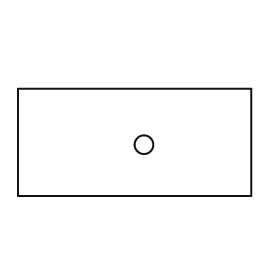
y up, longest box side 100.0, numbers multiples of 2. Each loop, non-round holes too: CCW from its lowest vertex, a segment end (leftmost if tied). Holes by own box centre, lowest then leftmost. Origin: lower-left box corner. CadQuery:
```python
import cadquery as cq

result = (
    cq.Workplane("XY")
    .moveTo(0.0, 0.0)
    .lineTo(100.0, 0.0)
    .lineTo(100.0, 46.0)
    .lineTo(0.0, 46.0)
    .close()
    .moveTo(54.0, 22.0)
    .circle(4.0)
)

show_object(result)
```